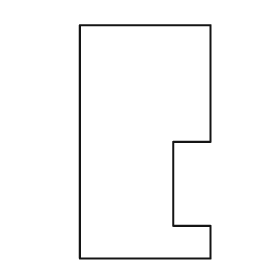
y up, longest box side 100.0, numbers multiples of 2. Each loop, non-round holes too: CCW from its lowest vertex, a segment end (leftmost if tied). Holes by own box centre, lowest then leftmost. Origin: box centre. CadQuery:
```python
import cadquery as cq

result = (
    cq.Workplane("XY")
    .moveTo(-28.0, -50.0)
    .lineTo(28.0, -50.0)
    .lineTo(28.0, -36.0)
    .lineTo(12.0, -36.0)
    .lineTo(12.0, 0.0)
    .lineTo(28.0, 0.0)
    .lineTo(28.0, 50.0)
    .lineTo(-28.0, 50.0)
    .close()
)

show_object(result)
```